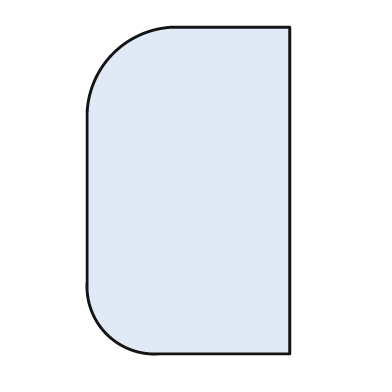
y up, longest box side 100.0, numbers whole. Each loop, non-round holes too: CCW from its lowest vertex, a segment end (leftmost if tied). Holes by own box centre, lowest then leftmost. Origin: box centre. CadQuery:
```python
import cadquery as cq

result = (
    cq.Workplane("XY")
    .moveTo(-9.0, -50.0)
    .lineTo(31.0, -50.0)
    .lineTo(31.0, 50.0)
    .lineTo(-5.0, 50.0)
    .threePointArc((-23.0, 42.0), (-31.0, 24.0))
    .lineTo(-31.0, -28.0)
    .threePointArc((-25.0, -44.0), (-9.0, -50.0))
    .close()
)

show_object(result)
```